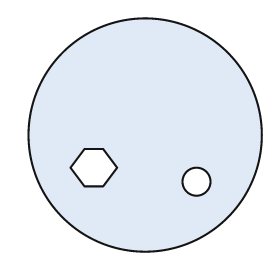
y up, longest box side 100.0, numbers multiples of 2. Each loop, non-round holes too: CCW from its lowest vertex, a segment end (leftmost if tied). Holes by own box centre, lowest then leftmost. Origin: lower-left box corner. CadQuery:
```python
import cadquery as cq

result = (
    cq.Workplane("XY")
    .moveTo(50.0, 50.0)
    .circle(50.0)
    .moveTo(72.0, 30.0)
    .circle(6.0)
    .moveTo(24.0, 28.0)
    .lineTo(32.0, 28.0)
    .lineTo(38.0, 36.0)
    .lineTo(32.0, 44.0)
    .lineTo(24.0, 44.0)
    .lineTo(18.0, 36.0)
    .close()
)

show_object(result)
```